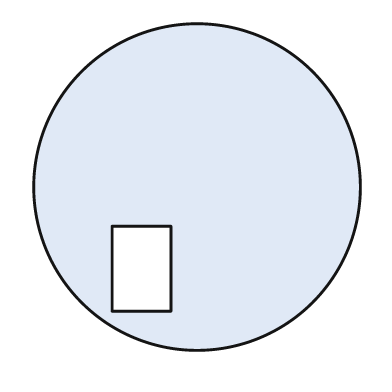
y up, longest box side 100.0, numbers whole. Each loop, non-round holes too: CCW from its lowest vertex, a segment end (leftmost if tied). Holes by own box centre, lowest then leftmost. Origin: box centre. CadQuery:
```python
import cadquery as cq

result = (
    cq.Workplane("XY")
    .moveTo(0.0, 0.0)
    .circle(50.0)
    .moveTo(-26.0, -38.0)
    .lineTo(-8.0, -38.0)
    .lineTo(-8.0, -12.0)
    .lineTo(-26.0, -12.0)
    .close()
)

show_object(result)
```